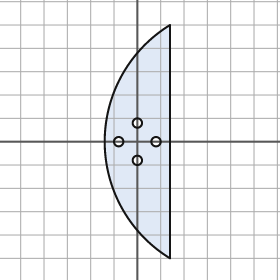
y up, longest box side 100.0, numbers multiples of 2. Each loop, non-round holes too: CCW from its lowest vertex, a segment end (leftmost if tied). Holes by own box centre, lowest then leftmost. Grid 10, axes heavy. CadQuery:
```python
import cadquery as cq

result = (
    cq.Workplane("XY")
    .moveTo(14.0, -50.0)
    .lineTo(14.0, 50.0)
    .threePointArc((-14.0, 0.0), (14.0, -50.0))
    .close()
    .moveTo(0.0, -8.0)
    .circle(2.0)
    .moveTo(-8.0, 0.0)
    .circle(2.0)
    .moveTo(8.0, 0.0)
    .circle(2.0)
    .moveTo(0.0, 8.0)
    .circle(2.0)
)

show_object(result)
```